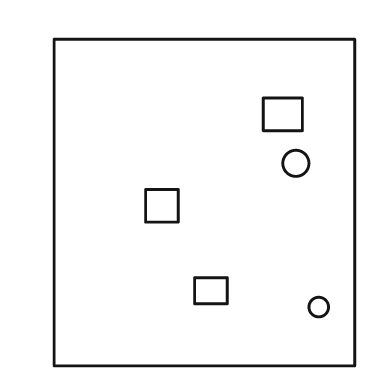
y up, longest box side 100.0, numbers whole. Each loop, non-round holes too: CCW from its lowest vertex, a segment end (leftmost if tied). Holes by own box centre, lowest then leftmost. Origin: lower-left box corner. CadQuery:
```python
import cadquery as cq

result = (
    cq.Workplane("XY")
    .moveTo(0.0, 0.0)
    .lineTo(92.0, 0.0)
    .lineTo(92.0, 100.0)
    .lineTo(0.0, 100.0)
    .close()
    .moveTo(81.0, 18.0)
    .circle(3.0)
    .moveTo(43.0, 19.0)
    .lineTo(53.0, 19.0)
    .lineTo(53.0, 27.0)
    .lineTo(43.0, 27.0)
    .close()
    .moveTo(28.0, 44.0)
    .lineTo(38.0, 44.0)
    .lineTo(38.0, 54.0)
    .lineTo(28.0, 54.0)
    .close()
    .moveTo(74.0, 62.0)
    .circle(4.0)
    .moveTo(64.0, 72.0)
    .lineTo(76.0, 72.0)
    .lineTo(76.0, 82.0)
    .lineTo(64.0, 82.0)
    .close()
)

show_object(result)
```